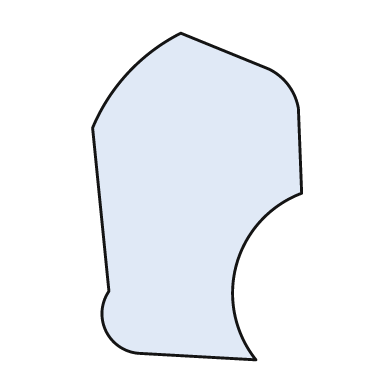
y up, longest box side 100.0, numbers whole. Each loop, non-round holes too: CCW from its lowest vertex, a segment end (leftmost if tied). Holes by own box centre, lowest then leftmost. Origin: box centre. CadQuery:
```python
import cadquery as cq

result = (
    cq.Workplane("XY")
    .moveTo(18.0, -50.0)
    .threePointArc((12.0, -21.0), (32.0, 1.0))
    .lineTo(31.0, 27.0)
    .threePointArc((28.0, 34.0), (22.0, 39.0))
    .lineTo(-5.0, 50.0)
    .threePointArc((-21.0, 38.0), (-32.0, 21.0))
    .lineTo(-27.0, -29.0)
    .threePointArc((-28.0, -41.0), (-18.0, -48.0))
    .close()
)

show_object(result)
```